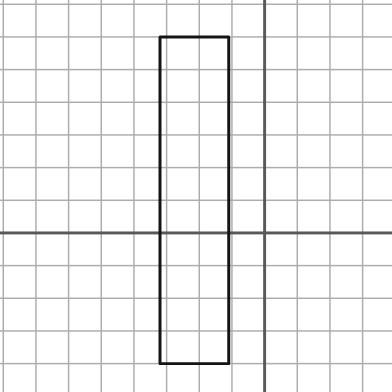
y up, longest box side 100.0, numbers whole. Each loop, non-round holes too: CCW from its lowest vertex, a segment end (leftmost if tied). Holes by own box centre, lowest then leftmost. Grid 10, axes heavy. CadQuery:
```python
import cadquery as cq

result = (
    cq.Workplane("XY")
    .moveTo(-32.0, -40.0)
    .lineTo(-11.0, -40.0)
    .lineTo(-11.0, 60.0)
    .lineTo(-32.0, 60.0)
    .close()
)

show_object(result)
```